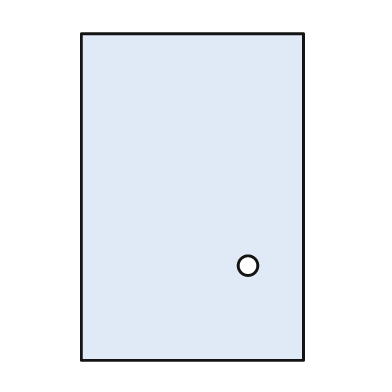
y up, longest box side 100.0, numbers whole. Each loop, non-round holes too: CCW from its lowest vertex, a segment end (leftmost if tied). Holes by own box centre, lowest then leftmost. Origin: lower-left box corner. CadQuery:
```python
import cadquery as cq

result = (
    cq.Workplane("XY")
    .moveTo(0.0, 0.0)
    .lineTo(68.0, 0.0)
    .lineTo(68.0, 100.0)
    .lineTo(0.0, 100.0)
    .close()
    .moveTo(51.0, 29.0)
    .circle(3.0)
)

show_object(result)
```